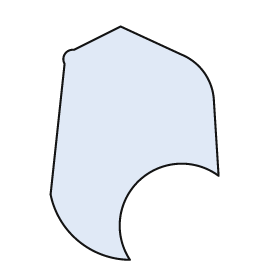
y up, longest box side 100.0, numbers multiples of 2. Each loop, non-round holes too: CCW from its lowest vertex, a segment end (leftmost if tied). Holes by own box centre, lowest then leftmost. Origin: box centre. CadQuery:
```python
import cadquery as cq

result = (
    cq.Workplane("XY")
    .moveTo(-2.0, -50.0)
    .threePointArc((2.0, -16.0), (36.0, -14.0))
    .lineTo(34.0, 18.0)
    .threePointArc((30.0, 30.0), (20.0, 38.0))
    .lineTo(-6.0, 50.0)
    .lineTo(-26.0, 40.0)
    .threePointArc((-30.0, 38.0), (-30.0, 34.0))
    .lineTo(-36.0, -22.0)
    .threePointArc((-24.0, -42.0), (-2.0, -50.0))
    .close()
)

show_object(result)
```